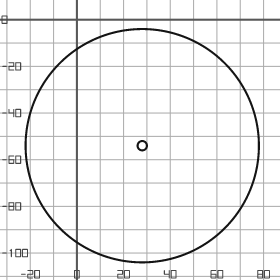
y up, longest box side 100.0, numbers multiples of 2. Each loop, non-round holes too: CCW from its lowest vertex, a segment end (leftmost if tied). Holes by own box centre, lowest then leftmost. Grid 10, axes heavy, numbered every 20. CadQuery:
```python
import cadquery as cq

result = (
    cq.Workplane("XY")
    .moveTo(28.0, -54.0)
    .circle(50.0)
    .moveTo(28.0, -54.0)
    .circle(2.0)
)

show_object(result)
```